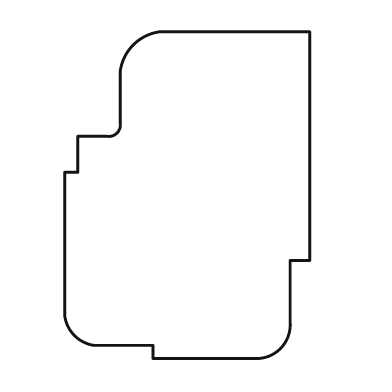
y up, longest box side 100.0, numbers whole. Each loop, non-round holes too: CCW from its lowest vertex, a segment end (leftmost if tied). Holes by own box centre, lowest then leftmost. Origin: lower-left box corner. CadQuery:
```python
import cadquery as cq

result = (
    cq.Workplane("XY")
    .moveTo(27.0, 0.0)
    .lineTo(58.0, 0.0)
    .threePointArc((66.0, 3.0), (69.0, 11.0))
    .lineTo(69.0, 30.0)
    .lineTo(75.0, 30.0)
    .lineTo(75.0, 100.0)
    .lineTo(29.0, 100.0)
    .threePointArc((21.0, 96.0), (17.0, 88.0))
    .lineTo(17.0, 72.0)
    .threePointArc((16.0, 69.0), (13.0, 68.0))
    .lineTo(4.0, 68.0)
    .lineTo(4.0, 57.0)
    .lineTo(0.0, 57.0)
    .lineTo(0.0, 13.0)
    .threePointArc((3.0, 7.0), (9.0, 4.0))
    .lineTo(27.0, 4.0)
    .close()
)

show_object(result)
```